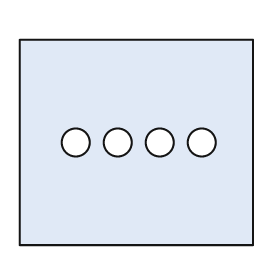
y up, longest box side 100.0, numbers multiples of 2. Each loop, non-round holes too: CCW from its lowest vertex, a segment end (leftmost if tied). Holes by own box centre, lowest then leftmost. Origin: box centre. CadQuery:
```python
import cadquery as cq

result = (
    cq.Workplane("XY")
    .moveTo(-50.0, -44.0)
    .lineTo(50.0, -44.0)
    .lineTo(50.0, 44.0)
    .lineTo(-50.0, 44.0)
    .close()
    .moveTo(-26.0, 0.0)
    .circle(6.0)
    .moveTo(-8.0, 0.0)
    .circle(6.0)
    .moveTo(10.0, 0.0)
    .circle(6.0)
    .moveTo(28.0, 0.0)
    .circle(6.0)
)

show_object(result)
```